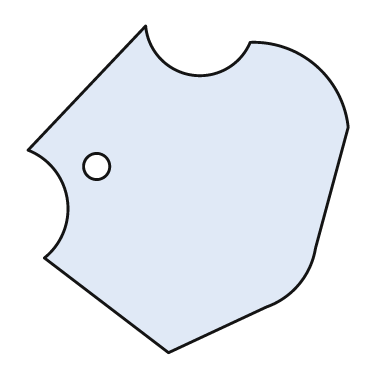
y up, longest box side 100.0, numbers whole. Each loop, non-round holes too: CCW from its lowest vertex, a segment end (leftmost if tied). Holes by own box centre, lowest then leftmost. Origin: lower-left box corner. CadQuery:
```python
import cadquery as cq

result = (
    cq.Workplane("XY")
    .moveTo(43.0, 0.0)
    .lineTo(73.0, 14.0)
    .threePointArc((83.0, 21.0), (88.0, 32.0))
    .lineTo(98.0, 69.0)
    .threePointArc((88.0, 88.0), (68.0, 95.0))
    .threePointArc((50.0, 85.0), (36.0, 100.0))
    .lineTo(0.0, 62.0)
    .threePointArc((12.0, 47.0), (5.0, 29.0))
    .close()
    .moveTo(21.0, 57.0)
    .circle(4.0)
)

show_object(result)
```